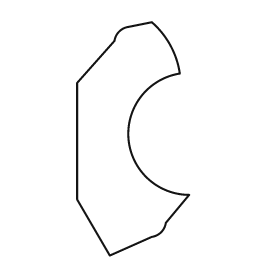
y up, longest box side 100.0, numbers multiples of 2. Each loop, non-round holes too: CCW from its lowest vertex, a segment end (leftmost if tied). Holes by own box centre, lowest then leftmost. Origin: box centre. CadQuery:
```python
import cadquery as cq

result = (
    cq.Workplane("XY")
    .moveTo(-10.0, -50.0)
    .lineTo(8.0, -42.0)
    .threePointArc((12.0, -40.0), (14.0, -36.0))
    .lineTo(24.0, -24.0)
    .threePointArc((-2.0, 0.0), (20.0, 28.0))
    .threePointArc((16.0, 40.0), (8.0, 50.0))
    .lineTo(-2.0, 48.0)
    .threePointArc((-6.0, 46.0), (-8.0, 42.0))
    .lineTo(-24.0, 24.0)
    .lineTo(-24.0, -26.0)
    .close()
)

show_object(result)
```